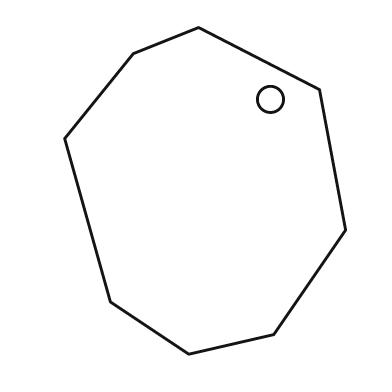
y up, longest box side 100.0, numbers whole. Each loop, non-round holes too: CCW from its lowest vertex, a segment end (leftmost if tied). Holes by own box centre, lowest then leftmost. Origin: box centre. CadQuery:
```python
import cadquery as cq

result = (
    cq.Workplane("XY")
    .moveTo(-5.0, -50.0)
    .lineTo(21.0, -44.0)
    .lineTo(43.0, -12.0)
    .lineTo(35.0, 31.0)
    .lineTo(-2.0, 50.0)
    .lineTo(-22.0, 42.0)
    .lineTo(-43.0, 16.0)
    .lineTo(-29.0, -34.0)
    .close()
    .moveTo(20.0, 28.0)
    .circle(4.0)
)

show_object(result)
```